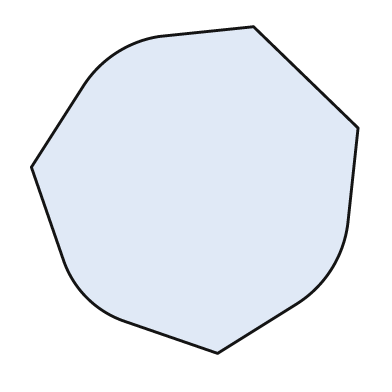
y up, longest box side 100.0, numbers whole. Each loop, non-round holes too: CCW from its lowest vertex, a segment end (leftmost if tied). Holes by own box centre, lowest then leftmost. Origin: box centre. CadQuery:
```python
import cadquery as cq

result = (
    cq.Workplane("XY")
    .moveTo(7.0, -50.0)
    .lineTo(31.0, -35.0)
    .threePointArc((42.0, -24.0), (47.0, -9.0))
    .lineTo(50.0, 19.0)
    .lineTo(18.0, 50.0)
    .lineTo(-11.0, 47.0)
    .threePointArc((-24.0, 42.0), (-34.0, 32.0))
    .lineTo(-50.0, 7.0)
    .lineTo(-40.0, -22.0)
    .threePointArc((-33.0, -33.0), (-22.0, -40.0))
    .close()
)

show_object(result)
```